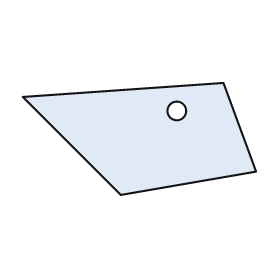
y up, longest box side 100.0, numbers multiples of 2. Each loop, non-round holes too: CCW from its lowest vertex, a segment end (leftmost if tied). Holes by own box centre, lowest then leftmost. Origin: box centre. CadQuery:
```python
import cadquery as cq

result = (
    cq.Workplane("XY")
    .moveTo(-8.0, -24.0)
    .lineTo(50.0, -14.0)
    .lineTo(36.0, 24.0)
    .lineTo(-50.0, 18.0)
    .close()
    .moveTo(16.0, 12.0)
    .circle(4.0)
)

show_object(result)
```